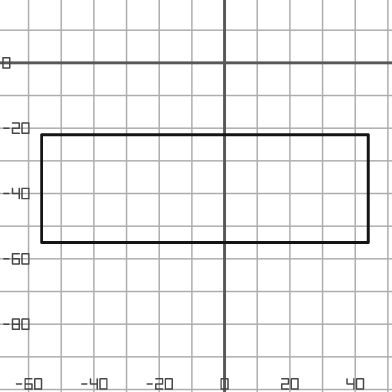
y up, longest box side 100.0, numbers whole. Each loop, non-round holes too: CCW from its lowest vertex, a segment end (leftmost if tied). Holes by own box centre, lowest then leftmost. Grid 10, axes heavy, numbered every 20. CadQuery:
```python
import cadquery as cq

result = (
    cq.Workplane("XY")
    .moveTo(-56.0, -55.0)
    .lineTo(44.0, -55.0)
    .lineTo(44.0, -22.0)
    .lineTo(-56.0, -22.0)
    .close()
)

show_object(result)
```